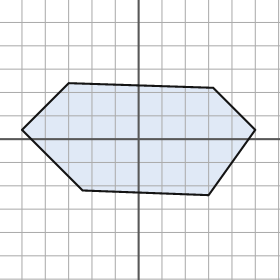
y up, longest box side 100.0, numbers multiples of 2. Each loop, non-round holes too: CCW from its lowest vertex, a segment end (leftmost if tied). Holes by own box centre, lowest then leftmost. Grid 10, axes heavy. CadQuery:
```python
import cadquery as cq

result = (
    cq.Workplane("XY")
    .moveTo(30.0, -24.0)
    .lineTo(50.0, 4.0)
    .lineTo(32.0, 22.0)
    .lineTo(-30.0, 24.0)
    .lineTo(-50.0, 4.0)
    .lineTo(-24.0, -22.0)
    .close()
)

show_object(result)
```